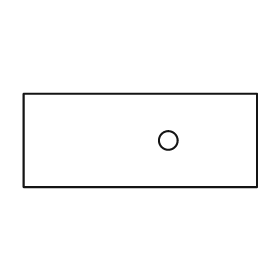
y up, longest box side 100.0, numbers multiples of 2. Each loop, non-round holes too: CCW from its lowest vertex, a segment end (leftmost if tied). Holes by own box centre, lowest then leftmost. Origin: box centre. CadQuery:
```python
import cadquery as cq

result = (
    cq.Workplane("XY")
    .moveTo(-50.0, -20.0)
    .lineTo(50.0, -20.0)
    .lineTo(50.0, 20.0)
    .lineTo(-50.0, 20.0)
    .close()
    .moveTo(12.0, 0.0)
    .circle(4.0)
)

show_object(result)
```